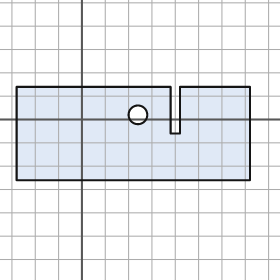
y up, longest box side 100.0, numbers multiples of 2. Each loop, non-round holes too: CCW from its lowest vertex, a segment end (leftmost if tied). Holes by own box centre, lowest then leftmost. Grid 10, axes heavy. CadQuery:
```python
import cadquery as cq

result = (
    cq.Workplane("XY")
    .moveTo(-28.0, -26.0)
    .lineTo(72.0, -26.0)
    .lineTo(72.0, 14.0)
    .lineTo(42.0, 14.0)
    .lineTo(42.0, -6.0)
    .lineTo(38.0, -6.0)
    .lineTo(38.0, 14.0)
    .lineTo(-28.0, 14.0)
    .close()
    .moveTo(24.0, 2.0)
    .circle(4.0)
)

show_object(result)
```